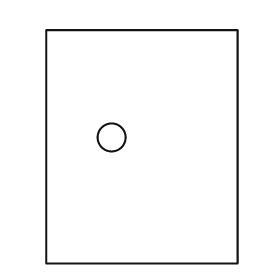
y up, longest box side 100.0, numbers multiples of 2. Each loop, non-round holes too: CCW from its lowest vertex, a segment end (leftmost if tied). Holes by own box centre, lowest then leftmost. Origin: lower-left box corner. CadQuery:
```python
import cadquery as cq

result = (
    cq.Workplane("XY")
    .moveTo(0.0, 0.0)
    .lineTo(82.0, 0.0)
    .lineTo(82.0, 100.0)
    .lineTo(0.0, 100.0)
    .close()
    .moveTo(28.0, 54.0)
    .circle(6.0)
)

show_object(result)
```